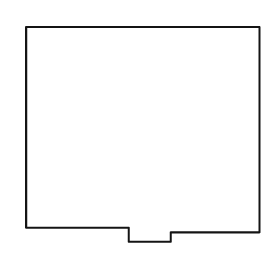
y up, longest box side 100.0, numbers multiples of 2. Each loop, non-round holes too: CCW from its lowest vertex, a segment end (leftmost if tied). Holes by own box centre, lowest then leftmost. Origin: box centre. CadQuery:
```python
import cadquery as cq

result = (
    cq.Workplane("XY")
    .moveTo(-6.0, -46.0)
    .lineTo(12.0, -46.0)
    .lineTo(12.0, -42.0)
    .lineTo(50.0, -42.0)
    .lineTo(50.0, 46.0)
    .lineTo(-50.0, 46.0)
    .lineTo(-50.0, -40.0)
    .lineTo(-6.0, -40.0)
    .close()
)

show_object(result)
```